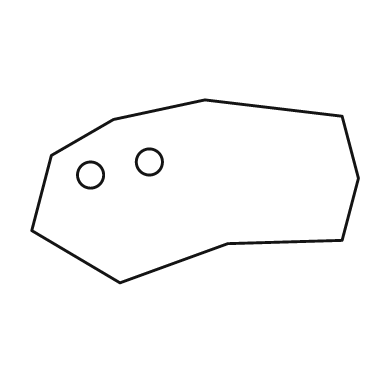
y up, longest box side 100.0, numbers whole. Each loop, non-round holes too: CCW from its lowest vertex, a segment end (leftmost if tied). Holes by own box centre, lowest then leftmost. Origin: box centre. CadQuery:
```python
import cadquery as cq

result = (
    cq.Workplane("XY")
    .moveTo(-23.0, -28.0)
    .lineTo(10.0, -16.0)
    .lineTo(45.0, -15.0)
    .lineTo(50.0, 4.0)
    .lineTo(45.0, 23.0)
    .lineTo(3.0, 28.0)
    .lineTo(-25.0, 22.0)
    .lineTo(-44.0, 11.0)
    .lineTo(-50.0, -12.0)
    .close()
    .moveTo(-32.0, 5.0)
    .circle(4.0)
    .moveTo(-14.0, 9.0)
    .circle(4.0)
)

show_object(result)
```